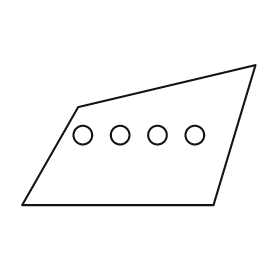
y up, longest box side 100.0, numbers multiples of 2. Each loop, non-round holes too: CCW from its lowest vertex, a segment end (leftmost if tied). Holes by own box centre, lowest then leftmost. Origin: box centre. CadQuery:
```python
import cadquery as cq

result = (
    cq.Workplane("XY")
    .moveTo(-50.0, -30.0)
    .lineTo(32.0, -30.0)
    .lineTo(50.0, 30.0)
    .lineTo(-26.0, 12.0)
    .close()
    .moveTo(-24.0, 0.0)
    .circle(4.0)
    .moveTo(-8.0, 0.0)
    .circle(4.0)
    .moveTo(8.0, 0.0)
    .circle(4.0)
    .moveTo(24.0, 0.0)
    .circle(4.0)
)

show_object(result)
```